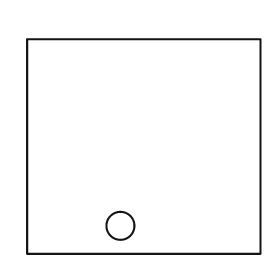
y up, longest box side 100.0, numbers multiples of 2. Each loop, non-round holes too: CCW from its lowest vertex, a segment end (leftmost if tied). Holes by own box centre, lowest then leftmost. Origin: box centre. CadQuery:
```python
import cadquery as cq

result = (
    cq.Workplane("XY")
    .moveTo(-50.0, -46.0)
    .lineTo(50.0, -46.0)
    .lineTo(50.0, 46.0)
    .lineTo(-50.0, 46.0)
    .close()
    .moveTo(-10.0, -34.0)
    .circle(6.0)
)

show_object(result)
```